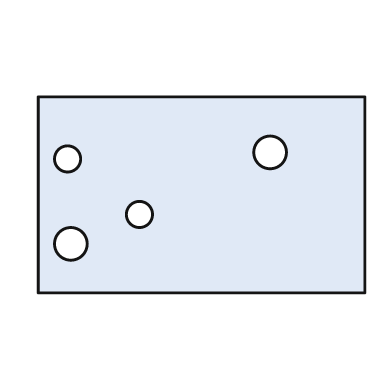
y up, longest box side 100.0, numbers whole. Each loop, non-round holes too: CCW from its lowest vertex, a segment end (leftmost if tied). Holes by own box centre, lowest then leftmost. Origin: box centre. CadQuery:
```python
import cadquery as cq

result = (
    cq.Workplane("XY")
    .moveTo(-50.0, -30.0)
    .lineTo(50.0, -30.0)
    .lineTo(50.0, 30.0)
    .lineTo(-50.0, 30.0)
    .close()
    .moveTo(-40.0, -15.0)
    .circle(5.0)
    .moveTo(-19.0, -6.0)
    .circle(4.0)
    .moveTo(-41.0, 11.0)
    .circle(4.0)
    .moveTo(21.0, 13.0)
    .circle(5.0)
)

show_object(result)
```